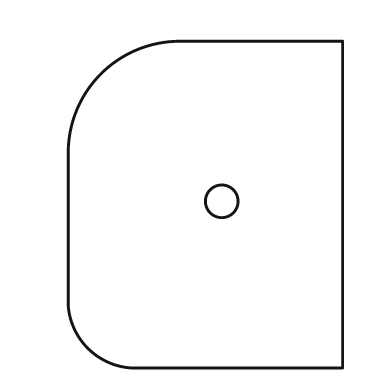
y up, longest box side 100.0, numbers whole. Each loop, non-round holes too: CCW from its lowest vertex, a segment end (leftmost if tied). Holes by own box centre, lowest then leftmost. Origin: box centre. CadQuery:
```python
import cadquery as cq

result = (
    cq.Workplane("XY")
    .moveTo(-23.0, -50.0)
    .lineTo(42.0, -50.0)
    .lineTo(42.0, 50.0)
    .lineTo(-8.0, 50.0)
    .threePointArc((-32.0, 40.0), (-42.0, 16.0))
    .lineTo(-42.0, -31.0)
    .threePointArc((-36.0, -44.0), (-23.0, -50.0))
    .close()
    .moveTo(5.0, 1.0)
    .circle(5.0)
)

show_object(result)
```